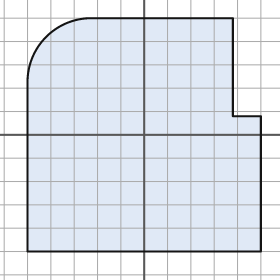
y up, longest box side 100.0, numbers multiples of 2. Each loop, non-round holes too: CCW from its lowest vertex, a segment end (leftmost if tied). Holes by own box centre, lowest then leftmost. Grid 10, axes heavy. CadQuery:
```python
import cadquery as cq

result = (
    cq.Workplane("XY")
    .moveTo(-50.0, -50.0)
    .lineTo(50.0, -50.0)
    .lineTo(50.0, 8.0)
    .lineTo(38.0, 8.0)
    .lineTo(38.0, 50.0)
    .lineTo(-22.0, 50.0)
    .threePointArc((-42.0, 42.0), (-50.0, 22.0))
    .close()
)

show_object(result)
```